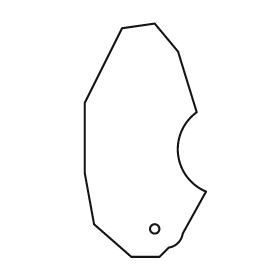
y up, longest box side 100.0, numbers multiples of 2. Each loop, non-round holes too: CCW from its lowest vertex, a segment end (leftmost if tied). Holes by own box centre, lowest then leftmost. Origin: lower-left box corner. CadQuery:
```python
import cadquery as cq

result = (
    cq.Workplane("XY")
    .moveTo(20.0, 0.0)
    .lineTo(32.0, 0.0)
    .lineTo(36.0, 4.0)
    .threePointArc((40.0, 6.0), (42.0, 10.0))
    .lineTo(52.0, 28.0)
    .threePointArc((40.0, 44.0), (48.0, 62.0))
    .lineTo(40.0, 88.0)
    .lineTo(30.0, 100.0)
    .lineTo(16.0, 98.0)
    .lineTo(0.0, 66.0)
    .lineTo(0.0, 36.0)
    .lineTo(4.0, 14.0)
    .close()
    .moveTo(30.0, 12.0)
    .circle(2.0)
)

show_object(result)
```